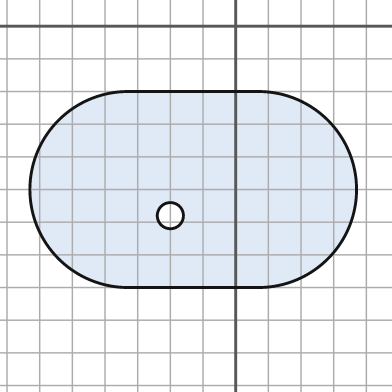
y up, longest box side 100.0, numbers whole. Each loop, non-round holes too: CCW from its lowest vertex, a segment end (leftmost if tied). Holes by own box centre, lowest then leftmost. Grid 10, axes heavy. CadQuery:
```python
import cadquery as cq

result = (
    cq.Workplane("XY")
    .moveTo(-33.0, -80.0)
    .lineTo(7.0, -80.0)
    .threePointArc((37.0, -50.0), (7.0, -20.0))
    .lineTo(-33.0, -20.0)
    .threePointArc((-63.0, -50.0), (-33.0, -80.0))
    .close()
    .moveTo(-20.0, -58.0)
    .circle(4.0)
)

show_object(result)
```